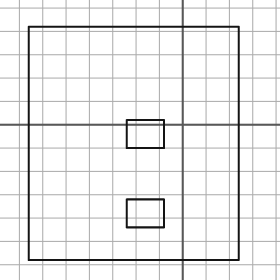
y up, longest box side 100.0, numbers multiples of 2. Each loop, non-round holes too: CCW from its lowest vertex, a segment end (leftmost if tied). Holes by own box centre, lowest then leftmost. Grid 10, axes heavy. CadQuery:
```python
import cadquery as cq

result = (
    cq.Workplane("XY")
    .moveTo(-66.0, -58.0)
    .lineTo(24.0, -58.0)
    .lineTo(24.0, 42.0)
    .lineTo(-66.0, 42.0)
    .close()
    .moveTo(-24.0, -44.0)
    .lineTo(-8.0, -44.0)
    .lineTo(-8.0, -32.0)
    .lineTo(-24.0, -32.0)
    .close()
    .moveTo(-24.0, -10.0)
    .lineTo(-8.0, -10.0)
    .lineTo(-8.0, 2.0)
    .lineTo(-24.0, 2.0)
    .close()
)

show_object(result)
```